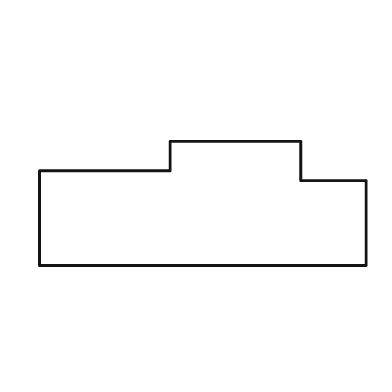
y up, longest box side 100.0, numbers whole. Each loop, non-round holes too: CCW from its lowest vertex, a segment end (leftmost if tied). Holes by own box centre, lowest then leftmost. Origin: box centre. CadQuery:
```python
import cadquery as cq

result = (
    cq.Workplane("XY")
    .moveTo(-50.0, -19.0)
    .lineTo(50.0, -19.0)
    .lineTo(50.0, 7.0)
    .lineTo(30.0, 7.0)
    .lineTo(30.0, 19.0)
    .lineTo(-10.0, 19.0)
    .lineTo(-10.0, 10.0)
    .lineTo(-50.0, 10.0)
    .close()
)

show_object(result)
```